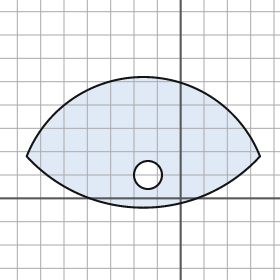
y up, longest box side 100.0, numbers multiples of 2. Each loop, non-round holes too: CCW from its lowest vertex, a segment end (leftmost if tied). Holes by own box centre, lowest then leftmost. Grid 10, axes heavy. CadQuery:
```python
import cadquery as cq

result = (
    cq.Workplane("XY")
    .moveTo(-66.0, 18.0)
    .threePointArc((-16.0, -4.0), (34.0, 18.0))
    .threePointArc((-16.0, 52.0), (-66.0, 18.0))
    .close()
    .moveTo(-14.0, 10.0)
    .circle(6.0)
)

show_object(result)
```